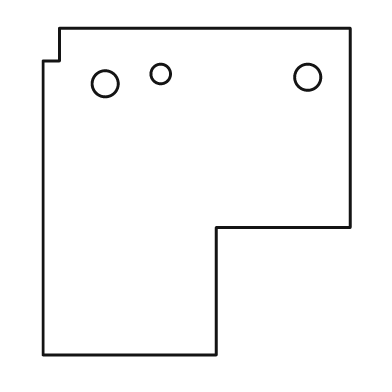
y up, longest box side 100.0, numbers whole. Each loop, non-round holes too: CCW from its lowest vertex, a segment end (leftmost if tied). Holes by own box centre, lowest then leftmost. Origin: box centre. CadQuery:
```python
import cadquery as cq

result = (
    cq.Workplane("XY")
    .moveTo(-47.0, -50.0)
    .lineTo(6.0, -50.0)
    .lineTo(6.0, -11.0)
    .lineTo(47.0, -11.0)
    .lineTo(47.0, 50.0)
    .lineTo(-42.0, 50.0)
    .lineTo(-42.0, 40.0)
    .lineTo(-47.0, 40.0)
    .close()
    .moveTo(-28.0, 33.0)
    .circle(4.0)
    .moveTo(34.0, 35.0)
    .circle(4.0)
    .moveTo(-11.0, 36.0)
    .circle(3.0)
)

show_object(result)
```